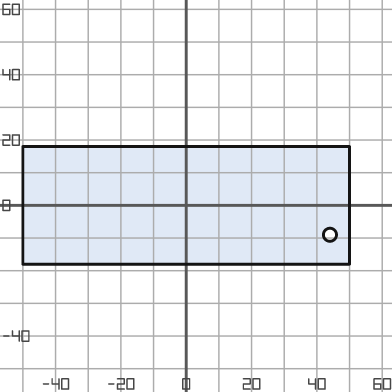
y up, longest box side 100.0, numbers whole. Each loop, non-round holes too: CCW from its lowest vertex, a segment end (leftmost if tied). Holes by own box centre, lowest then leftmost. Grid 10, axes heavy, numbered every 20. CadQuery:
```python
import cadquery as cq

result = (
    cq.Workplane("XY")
    .moveTo(-50.0, -18.0)
    .lineTo(50.0, -18.0)
    .lineTo(50.0, 18.0)
    .lineTo(-50.0, 18.0)
    .close()
    .moveTo(44.0, -9.0)
    .circle(2.0)
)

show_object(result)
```